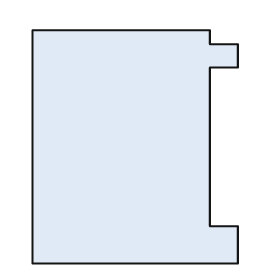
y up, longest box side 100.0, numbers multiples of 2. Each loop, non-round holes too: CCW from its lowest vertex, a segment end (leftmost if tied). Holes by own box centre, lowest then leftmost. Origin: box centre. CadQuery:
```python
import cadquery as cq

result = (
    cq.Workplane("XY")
    .moveTo(-44.0, -50.0)
    .lineTo(44.0, -50.0)
    .lineTo(44.0, -34.0)
    .lineTo(32.0, -34.0)
    .lineTo(32.0, 34.0)
    .lineTo(44.0, 34.0)
    .lineTo(44.0, 44.0)
    .lineTo(32.0, 44.0)
    .lineTo(32.0, 50.0)
    .lineTo(-44.0, 50.0)
    .close()
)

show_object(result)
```